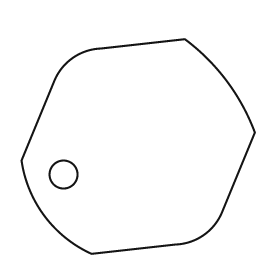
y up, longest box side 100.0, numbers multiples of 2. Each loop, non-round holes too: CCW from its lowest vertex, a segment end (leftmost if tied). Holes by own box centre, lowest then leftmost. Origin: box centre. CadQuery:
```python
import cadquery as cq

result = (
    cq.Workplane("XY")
    .moveTo(-20.0, -46.0)
    .lineTo(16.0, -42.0)
    .threePointArc((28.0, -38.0), (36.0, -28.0))
    .lineTo(50.0, 6.0)
    .threePointArc((38.0, 28.0), (20.0, 46.0))
    .lineTo(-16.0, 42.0)
    .threePointArc((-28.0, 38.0), (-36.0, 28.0))
    .lineTo(-50.0, -6.0)
    .threePointArc((-40.0, -30.0), (-20.0, -46.0))
    .close()
    .moveTo(-32.0, -12.0)
    .circle(6.0)
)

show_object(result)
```